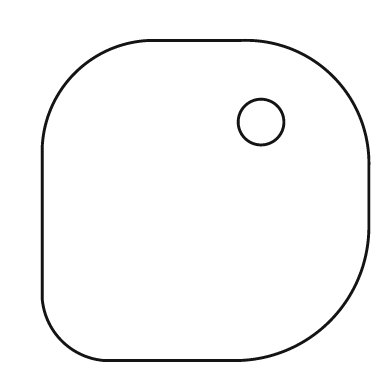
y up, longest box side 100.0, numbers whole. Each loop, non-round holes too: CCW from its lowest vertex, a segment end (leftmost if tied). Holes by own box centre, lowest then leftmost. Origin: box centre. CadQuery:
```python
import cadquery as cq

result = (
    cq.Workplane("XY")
    .moveTo(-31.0, -49.0)
    .lineTo(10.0, -49.0)
    .threePointArc((38.0, -37.0), (50.0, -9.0))
    .lineTo(50.0, 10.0)
    .threePointArc((39.0, 38.0), (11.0, 49.0))
    .lineTo(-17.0, 49.0)
    .threePointArc((-40.0, 39.0), (-50.0, 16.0))
    .lineTo(-50.0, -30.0)
    .threePointArc((-44.0, -43.0), (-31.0, -49.0))
    .close()
    .moveTo(17.0, 24.0)
    .circle(7.0)
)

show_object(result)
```